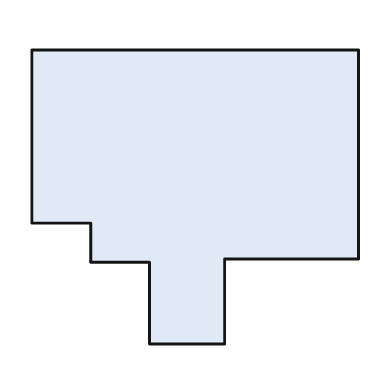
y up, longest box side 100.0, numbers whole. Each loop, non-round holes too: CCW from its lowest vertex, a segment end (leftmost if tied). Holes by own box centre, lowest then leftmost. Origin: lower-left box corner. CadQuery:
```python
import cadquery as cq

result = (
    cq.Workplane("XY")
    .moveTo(36.0, 0.0)
    .lineTo(59.0, 0.0)
    .lineTo(59.0, 26.0)
    .lineTo(100.0, 26.0)
    .lineTo(100.0, 90.0)
    .lineTo(0.0, 90.0)
    .lineTo(0.0, 37.0)
    .lineTo(18.0, 37.0)
    .lineTo(18.0, 25.0)
    .lineTo(36.0, 25.0)
    .close()
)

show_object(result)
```